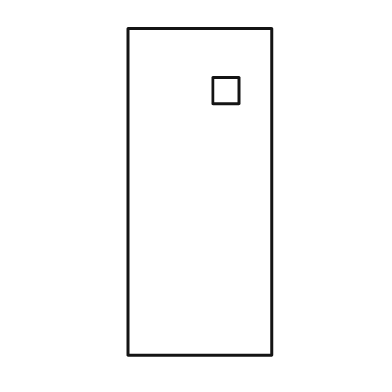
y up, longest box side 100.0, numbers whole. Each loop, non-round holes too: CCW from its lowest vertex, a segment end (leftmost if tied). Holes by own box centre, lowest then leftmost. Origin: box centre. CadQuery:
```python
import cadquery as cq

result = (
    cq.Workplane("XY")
    .moveTo(-22.0, -50.0)
    .lineTo(22.0, -50.0)
    .lineTo(22.0, 50.0)
    .lineTo(-22.0, 50.0)
    .close()
    .moveTo(4.0, 27.0)
    .lineTo(12.0, 27.0)
    .lineTo(12.0, 35.0)
    .lineTo(4.0, 35.0)
    .close()
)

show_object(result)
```